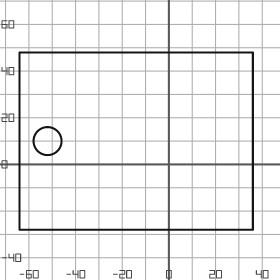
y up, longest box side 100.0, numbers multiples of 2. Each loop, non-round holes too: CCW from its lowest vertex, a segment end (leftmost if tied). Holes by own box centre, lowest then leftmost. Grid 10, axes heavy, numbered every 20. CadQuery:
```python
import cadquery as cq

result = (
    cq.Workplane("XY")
    .moveTo(-64.0, -28.0)
    .lineTo(36.0, -28.0)
    .lineTo(36.0, 48.0)
    .lineTo(-64.0, 48.0)
    .close()
    .moveTo(-52.0, 10.0)
    .circle(6.0)
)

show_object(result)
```